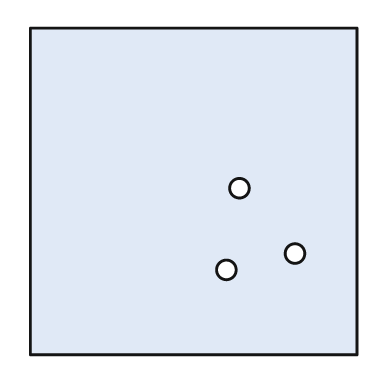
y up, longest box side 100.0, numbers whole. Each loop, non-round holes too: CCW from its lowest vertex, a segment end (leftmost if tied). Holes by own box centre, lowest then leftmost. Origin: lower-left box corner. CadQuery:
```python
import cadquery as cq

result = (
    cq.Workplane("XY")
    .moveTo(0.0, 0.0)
    .lineTo(100.0, 0.0)
    .lineTo(100.0, 100.0)
    .lineTo(0.0, 100.0)
    .close()
    .moveTo(60.0, 26.0)
    .circle(3.0)
    .moveTo(81.0, 31.0)
    .circle(3.0)
    .moveTo(64.0, 51.0)
    .circle(3.0)
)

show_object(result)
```